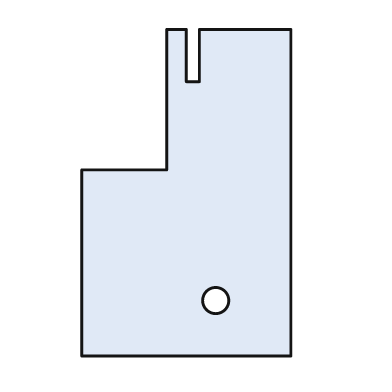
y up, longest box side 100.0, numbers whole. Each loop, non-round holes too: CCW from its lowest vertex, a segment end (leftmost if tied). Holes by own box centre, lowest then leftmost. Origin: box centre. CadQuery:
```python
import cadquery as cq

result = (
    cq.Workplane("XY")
    .moveTo(-32.0, -50.0)
    .lineTo(32.0, -50.0)
    .lineTo(32.0, 50.0)
    .lineTo(4.0, 50.0)
    .lineTo(4.0, 34.0)
    .lineTo(0.0, 34.0)
    .lineTo(0.0, 50.0)
    .lineTo(-6.0, 50.0)
    .lineTo(-6.0, 7.0)
    .lineTo(-32.0, 7.0)
    .close()
    .moveTo(9.0, -33.0)
    .circle(4.0)
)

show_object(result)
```